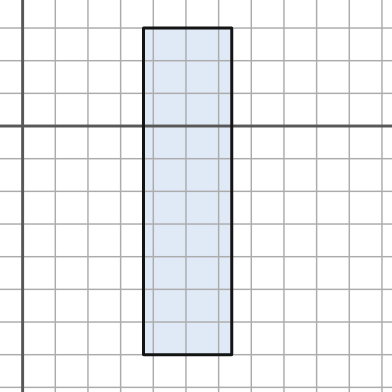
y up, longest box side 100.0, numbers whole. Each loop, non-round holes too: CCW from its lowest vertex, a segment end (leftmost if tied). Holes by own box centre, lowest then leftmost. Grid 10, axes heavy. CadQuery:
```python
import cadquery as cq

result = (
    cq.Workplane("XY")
    .moveTo(37.0, -70.0)
    .lineTo(64.0, -70.0)
    .lineTo(64.0, 30.0)
    .lineTo(37.0, 30.0)
    .close()
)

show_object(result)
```